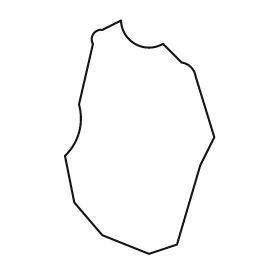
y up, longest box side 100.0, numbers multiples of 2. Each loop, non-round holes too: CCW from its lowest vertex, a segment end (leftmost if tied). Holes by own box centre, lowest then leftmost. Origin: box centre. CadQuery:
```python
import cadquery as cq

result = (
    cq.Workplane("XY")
    .moveTo(4.0, -50.0)
    .lineTo(16.0, -46.0)
    .lineTo(26.0, -12.0)
    .lineTo(32.0, 0.0)
    .lineTo(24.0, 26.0)
    .threePointArc((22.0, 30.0), (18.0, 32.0))
    .lineTo(10.0, 40.0)
    .threePointArc((-2.0, 40.0), (-8.0, 50.0))
    .lineTo(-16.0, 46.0)
    .threePointArc((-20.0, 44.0), (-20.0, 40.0))
    .lineTo(-26.0, 14.0)
    .threePointArc((-26.0, 2.0), (-32.0, -8.0))
    .lineTo(-28.0, -28.0)
    .lineTo(-16.0, -42.0)
    .close()
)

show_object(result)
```